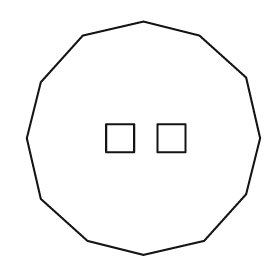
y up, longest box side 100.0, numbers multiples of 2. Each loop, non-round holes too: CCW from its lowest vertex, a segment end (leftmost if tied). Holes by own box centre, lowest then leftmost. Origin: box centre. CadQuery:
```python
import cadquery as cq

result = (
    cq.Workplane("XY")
    .moveTo(0.0, -50.0)
    .lineTo(26.0, -44.0)
    .lineTo(44.0, -24.0)
    .lineTo(50.0, 0.0)
    .lineTo(44.0, 26.0)
    .lineTo(24.0, 44.0)
    .lineTo(0.0, 50.0)
    .lineTo(-26.0, 44.0)
    .lineTo(-44.0, 24.0)
    .lineTo(-50.0, 0.0)
    .lineTo(-44.0, -26.0)
    .lineTo(-24.0, -44.0)
    .close()
    .moveTo(-16.0, -6.0)
    .lineTo(-4.0, -6.0)
    .lineTo(-4.0, 6.0)
    .lineTo(-16.0, 6.0)
    .close()
    .moveTo(6.0, -6.0)
    .lineTo(18.0, -6.0)
    .lineTo(18.0, 6.0)
    .lineTo(6.0, 6.0)
    .close()
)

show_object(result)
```